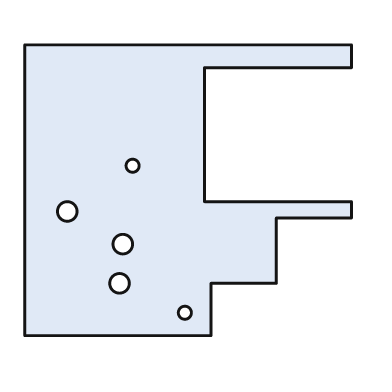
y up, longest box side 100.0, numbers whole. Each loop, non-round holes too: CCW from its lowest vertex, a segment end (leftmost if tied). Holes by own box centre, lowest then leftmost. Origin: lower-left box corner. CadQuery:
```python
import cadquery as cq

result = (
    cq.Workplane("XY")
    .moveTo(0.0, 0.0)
    .lineTo(57.0, 0.0)
    .lineTo(57.0, 16.0)
    .lineTo(77.0, 16.0)
    .lineTo(77.0, 36.0)
    .lineTo(100.0, 36.0)
    .lineTo(100.0, 41.0)
    .lineTo(55.0, 41.0)
    .lineTo(55.0, 82.0)
    .lineTo(100.0, 82.0)
    .lineTo(100.0, 89.0)
    .lineTo(0.0, 89.0)
    .close()
    .moveTo(49.0, 7.0)
    .circle(2.0)
    .moveTo(29.0, 16.0)
    .circle(3.0)
    .moveTo(30.0, 28.0)
    .circle(3.0)
    .moveTo(13.0, 38.0)
    .circle(3.0)
    .moveTo(33.0, 52.0)
    .circle(2.0)
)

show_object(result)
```